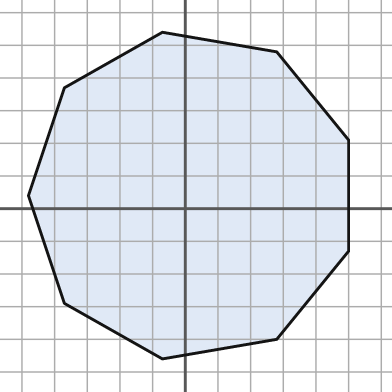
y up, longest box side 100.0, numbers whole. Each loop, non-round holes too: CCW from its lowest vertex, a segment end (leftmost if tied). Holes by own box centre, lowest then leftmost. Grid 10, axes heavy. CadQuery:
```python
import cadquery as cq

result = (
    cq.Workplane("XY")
    .moveTo(-7.0, -46.0)
    .lineTo(28.0, -40.0)
    .lineTo(50.0, -13.0)
    .lineTo(50.0, 21.0)
    .lineTo(28.0, 48.0)
    .lineTo(-7.0, 54.0)
    .lineTo(-37.0, 37.0)
    .lineTo(-48.0, 4.0)
    .lineTo(-37.0, -29.0)
    .close()
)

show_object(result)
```